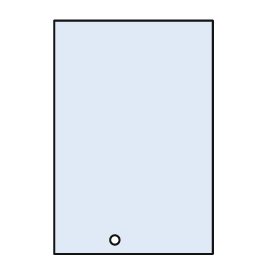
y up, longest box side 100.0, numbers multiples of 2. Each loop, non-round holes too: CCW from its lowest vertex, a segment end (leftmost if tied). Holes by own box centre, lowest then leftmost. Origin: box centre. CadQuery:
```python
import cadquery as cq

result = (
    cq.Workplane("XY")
    .moveTo(-34.0, -50.0)
    .lineTo(34.0, -50.0)
    .lineTo(34.0, 50.0)
    .lineTo(-34.0, 50.0)
    .close()
    .moveTo(-8.0, -44.0)
    .circle(2.0)
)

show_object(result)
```